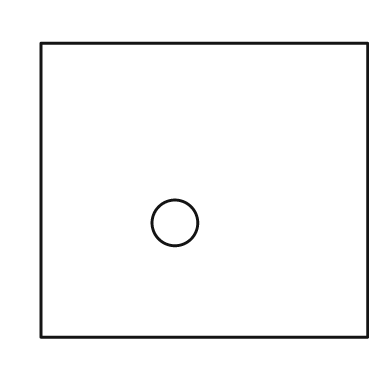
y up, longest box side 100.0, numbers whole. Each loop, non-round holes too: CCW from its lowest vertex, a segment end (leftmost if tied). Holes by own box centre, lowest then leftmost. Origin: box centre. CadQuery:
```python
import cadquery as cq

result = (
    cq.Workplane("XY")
    .moveTo(-50.0, -45.0)
    .lineTo(50.0, -45.0)
    .lineTo(50.0, 45.0)
    .lineTo(-50.0, 45.0)
    .close()
    .moveTo(-9.0, -10.0)
    .circle(7.0)
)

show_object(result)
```